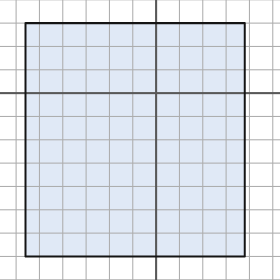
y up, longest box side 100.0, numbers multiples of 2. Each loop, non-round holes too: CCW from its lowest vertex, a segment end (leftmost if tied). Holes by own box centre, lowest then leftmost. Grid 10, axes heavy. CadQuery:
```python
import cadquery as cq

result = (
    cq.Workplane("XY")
    .moveTo(-56.0, -70.0)
    .lineTo(38.0, -70.0)
    .lineTo(38.0, 30.0)
    .lineTo(-56.0, 30.0)
    .close()
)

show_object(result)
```